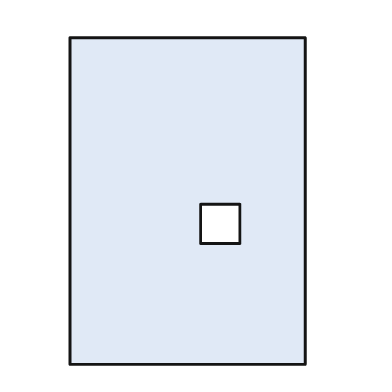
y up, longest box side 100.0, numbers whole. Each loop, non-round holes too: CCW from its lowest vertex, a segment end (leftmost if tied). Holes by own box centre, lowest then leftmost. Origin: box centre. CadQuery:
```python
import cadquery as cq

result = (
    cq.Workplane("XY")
    .moveTo(-36.0, -50.0)
    .lineTo(36.0, -50.0)
    .lineTo(36.0, 50.0)
    .lineTo(-36.0, 50.0)
    .close()
    .moveTo(4.0, -13.0)
    .lineTo(16.0, -13.0)
    .lineTo(16.0, -1.0)
    .lineTo(4.0, -1.0)
    .close()
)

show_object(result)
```